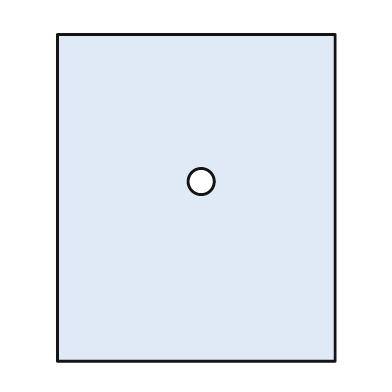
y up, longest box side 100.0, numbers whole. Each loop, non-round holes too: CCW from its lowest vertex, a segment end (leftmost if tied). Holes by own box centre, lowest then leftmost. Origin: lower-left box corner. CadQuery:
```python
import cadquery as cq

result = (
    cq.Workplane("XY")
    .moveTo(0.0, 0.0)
    .lineTo(85.0, 0.0)
    .lineTo(85.0, 100.0)
    .lineTo(0.0, 100.0)
    .close()
    .moveTo(44.0, 55.0)
    .circle(4.0)
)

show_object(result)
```